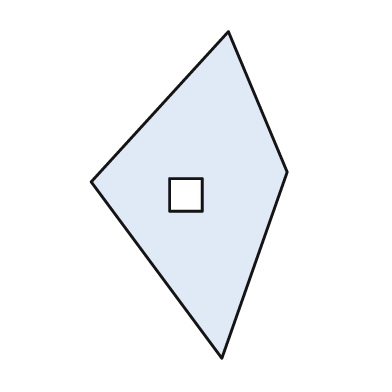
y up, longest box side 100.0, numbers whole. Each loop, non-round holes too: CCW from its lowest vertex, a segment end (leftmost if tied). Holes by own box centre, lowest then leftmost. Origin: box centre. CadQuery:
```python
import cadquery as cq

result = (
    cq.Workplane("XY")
    .moveTo(10.0, -50.0)
    .lineTo(30.0, 7.0)
    .lineTo(12.0, 50.0)
    .lineTo(-30.0, 4.0)
    .close()
    .moveTo(-6.0, -5.0)
    .lineTo(4.0, -5.0)
    .lineTo(4.0, 5.0)
    .lineTo(-6.0, 5.0)
    .close()
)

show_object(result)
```